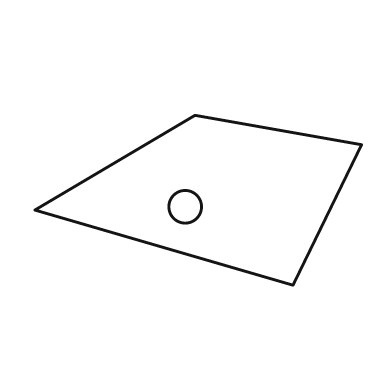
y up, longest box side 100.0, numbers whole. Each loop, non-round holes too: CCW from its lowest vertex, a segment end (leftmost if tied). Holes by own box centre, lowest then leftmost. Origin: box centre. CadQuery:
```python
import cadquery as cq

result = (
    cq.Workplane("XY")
    .moveTo(29.0, -26.0)
    .lineTo(50.0, 17.0)
    .lineTo(-1.0, 26.0)
    .lineTo(-50.0, -3.0)
    .close()
    .moveTo(-4.0, -2.0)
    .circle(5.0)
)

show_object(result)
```